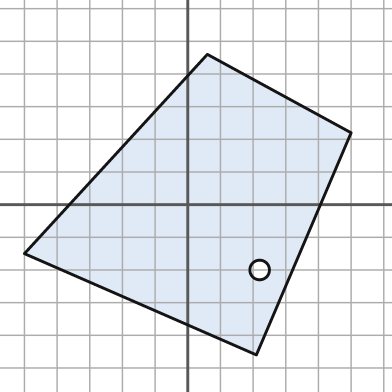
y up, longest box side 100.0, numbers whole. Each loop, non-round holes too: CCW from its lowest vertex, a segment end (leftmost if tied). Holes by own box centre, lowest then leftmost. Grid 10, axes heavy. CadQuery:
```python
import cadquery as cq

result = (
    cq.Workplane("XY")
    .moveTo(21.0, -46.0)
    .lineTo(50.0, 22.0)
    .lineTo(6.0, 46.0)
    .lineTo(-50.0, -15.0)
    .close()
    .moveTo(22.0, -20.0)
    .circle(3.0)
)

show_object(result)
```